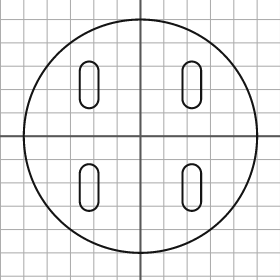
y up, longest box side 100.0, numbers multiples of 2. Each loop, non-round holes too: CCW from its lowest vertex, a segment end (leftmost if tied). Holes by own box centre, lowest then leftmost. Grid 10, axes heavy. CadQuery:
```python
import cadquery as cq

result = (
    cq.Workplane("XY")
    .moveTo(0.0, 0.0)
    .circle(50.0)
    .moveTo(-26.0, -28.0)
    .threePointArc((-22.0, -32.0), (-18.0, -28.0))
    .lineTo(-18.0, -16.0)
    .threePointArc((-22.0, -12.0), (-26.0, -16.0))
    .close()
    .moveTo(18.0, -28.0)
    .threePointArc((22.0, -32.0), (26.0, -28.0))
    .lineTo(26.0, -16.0)
    .threePointArc((22.0, -12.0), (18.0, -16.0))
    .close()
    .moveTo(-26.0, 16.0)
    .threePointArc((-22.0, 12.0), (-18.0, 16.0))
    .lineTo(-18.0, 28.0)
    .threePointArc((-22.0, 32.0), (-26.0, 28.0))
    .close()
    .moveTo(18.0, 16.0)
    .threePointArc((22.0, 12.0), (26.0, 16.0))
    .lineTo(26.0, 28.0)
    .threePointArc((22.0, 32.0), (18.0, 28.0))
    .close()
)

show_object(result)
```